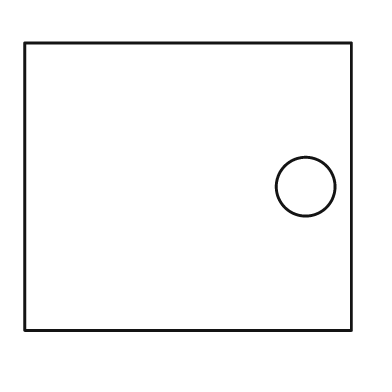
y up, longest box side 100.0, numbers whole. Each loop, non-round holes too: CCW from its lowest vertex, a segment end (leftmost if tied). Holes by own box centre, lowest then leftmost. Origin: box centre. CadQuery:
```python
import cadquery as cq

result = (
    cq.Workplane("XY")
    .moveTo(-50.0, -44.0)
    .lineTo(50.0, -44.0)
    .lineTo(50.0, 44.0)
    .lineTo(-50.0, 44.0)
    .close()
    .moveTo(36.0, 0.0)
    .circle(9.0)
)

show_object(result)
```